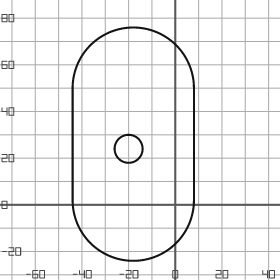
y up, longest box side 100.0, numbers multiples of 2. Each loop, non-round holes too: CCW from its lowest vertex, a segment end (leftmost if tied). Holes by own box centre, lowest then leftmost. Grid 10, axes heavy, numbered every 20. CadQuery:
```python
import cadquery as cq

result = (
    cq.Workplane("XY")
    .moveTo(-44.0, 2.0)
    .threePointArc((-18.0, -24.0), (8.0, 2.0))
    .lineTo(8.0, 50.0)
    .threePointArc((-18.0, 76.0), (-44.0, 50.0))
    .close()
    .moveTo(-20.0, 24.0)
    .circle(6.0)
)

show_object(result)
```